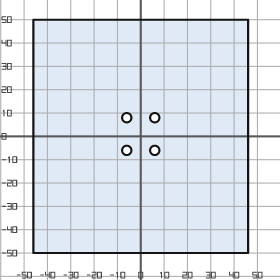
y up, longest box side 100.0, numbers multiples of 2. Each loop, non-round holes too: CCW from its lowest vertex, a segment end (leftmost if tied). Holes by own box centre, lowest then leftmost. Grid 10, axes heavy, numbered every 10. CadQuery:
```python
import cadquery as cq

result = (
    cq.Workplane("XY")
    .moveTo(-46.0, -50.0)
    .lineTo(46.0, -50.0)
    .lineTo(46.0, 50.0)
    .lineTo(-46.0, 50.0)
    .close()
    .moveTo(-6.0, -6.0)
    .circle(2.0)
    .moveTo(6.0, -6.0)
    .circle(2.0)
    .moveTo(-6.0, 8.0)
    .circle(2.0)
    .moveTo(6.0, 8.0)
    .circle(2.0)
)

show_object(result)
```